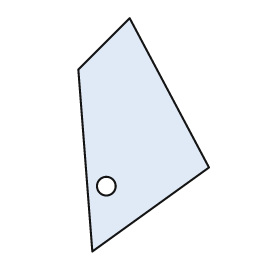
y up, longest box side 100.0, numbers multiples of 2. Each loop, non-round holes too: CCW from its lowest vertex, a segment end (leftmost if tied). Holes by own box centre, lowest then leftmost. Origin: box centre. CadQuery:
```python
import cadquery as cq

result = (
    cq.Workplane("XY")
    .moveTo(-22.0, -50.0)
    .lineTo(28.0, -14.0)
    .lineTo(-6.0, 50.0)
    .lineTo(-28.0, 28.0)
    .close()
    .moveTo(-16.0, -22.0)
    .circle(4.0)
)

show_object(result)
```